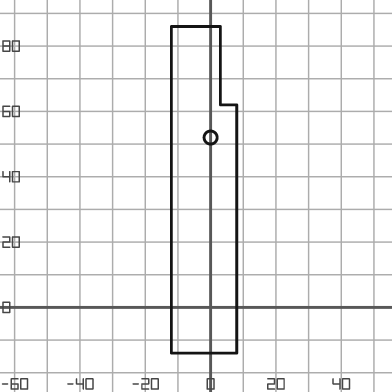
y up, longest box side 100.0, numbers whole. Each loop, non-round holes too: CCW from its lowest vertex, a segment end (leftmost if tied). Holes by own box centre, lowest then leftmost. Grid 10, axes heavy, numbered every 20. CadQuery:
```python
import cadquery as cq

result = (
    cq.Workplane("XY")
    .moveTo(-12.0, -14.0)
    .lineTo(8.0, -14.0)
    .lineTo(8.0, 62.0)
    .lineTo(3.0, 62.0)
    .lineTo(3.0, 86.0)
    .lineTo(-12.0, 86.0)
    .close()
    .moveTo(0.0, 52.0)
    .circle(2.0)
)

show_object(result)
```